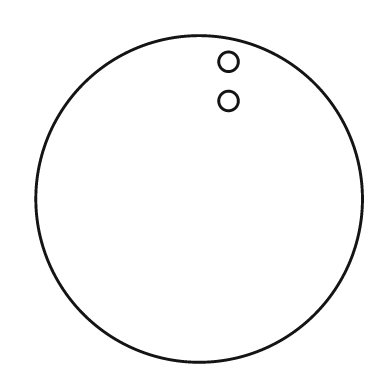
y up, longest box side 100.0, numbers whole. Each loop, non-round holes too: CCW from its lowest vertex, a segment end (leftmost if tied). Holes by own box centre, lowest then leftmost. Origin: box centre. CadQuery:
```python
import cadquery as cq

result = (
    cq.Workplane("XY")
    .moveTo(0.0, 0.0)
    .circle(50.0)
    .moveTo(9.0, 30.0)
    .circle(3.0)
    .moveTo(9.0, 42.0)
    .circle(3.0)
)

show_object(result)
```